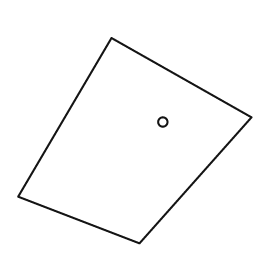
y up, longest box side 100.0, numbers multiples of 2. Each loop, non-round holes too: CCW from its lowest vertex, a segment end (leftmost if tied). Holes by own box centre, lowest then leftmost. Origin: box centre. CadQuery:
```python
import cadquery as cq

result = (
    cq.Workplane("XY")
    .moveTo(2.0, -44.0)
    .lineTo(50.0, 10.0)
    .lineTo(-10.0, 44.0)
    .lineTo(-50.0, -24.0)
    .close()
    .moveTo(12.0, 8.0)
    .circle(2.0)
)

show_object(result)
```